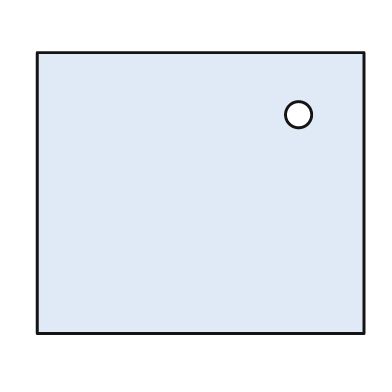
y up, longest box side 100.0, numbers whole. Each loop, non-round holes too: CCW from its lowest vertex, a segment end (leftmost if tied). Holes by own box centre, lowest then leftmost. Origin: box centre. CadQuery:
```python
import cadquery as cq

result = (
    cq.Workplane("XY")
    .moveTo(-50.0, -43.0)
    .lineTo(50.0, -43.0)
    .lineTo(50.0, 43.0)
    .lineTo(-50.0, 43.0)
    .close()
    .moveTo(30.0, 24.0)
    .circle(4.0)
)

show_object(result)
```